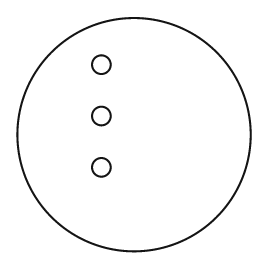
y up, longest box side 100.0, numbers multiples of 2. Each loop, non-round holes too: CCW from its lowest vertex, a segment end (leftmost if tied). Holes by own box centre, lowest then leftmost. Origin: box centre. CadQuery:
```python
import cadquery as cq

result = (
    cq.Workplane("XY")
    .moveTo(0.0, 0.0)
    .circle(50.0)
    .moveTo(-14.0, -14.0)
    .circle(4.0)
    .moveTo(-14.0, 8.0)
    .circle(4.0)
    .moveTo(-14.0, 30.0)
    .circle(4.0)
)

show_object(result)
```